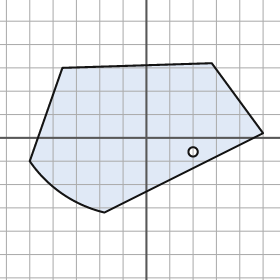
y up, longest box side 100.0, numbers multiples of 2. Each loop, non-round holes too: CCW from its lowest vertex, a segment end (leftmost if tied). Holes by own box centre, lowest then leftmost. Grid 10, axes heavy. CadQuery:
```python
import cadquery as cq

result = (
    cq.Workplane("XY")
    .moveTo(-18.0, -32.0)
    .lineTo(50.0, 2.0)
    .lineTo(28.0, 32.0)
    .lineTo(-36.0, 30.0)
    .lineTo(-50.0, -10.0)
    .threePointArc((-36.0, -24.0), (-18.0, -32.0))
    .close()
    .moveTo(20.0, -6.0)
    .circle(2.0)
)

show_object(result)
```